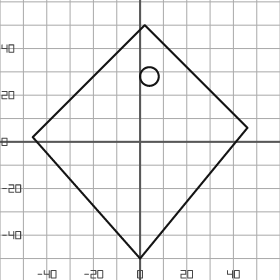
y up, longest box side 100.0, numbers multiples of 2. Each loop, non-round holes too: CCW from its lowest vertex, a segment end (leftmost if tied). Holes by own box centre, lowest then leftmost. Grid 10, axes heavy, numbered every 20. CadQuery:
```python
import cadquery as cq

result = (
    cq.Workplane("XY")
    .moveTo(0.0, -50.0)
    .lineTo(46.0, 6.0)
    .lineTo(2.0, 50.0)
    .lineTo(-46.0, 2.0)
    .close()
    .moveTo(4.0, 28.0)
    .circle(4.0)
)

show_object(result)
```